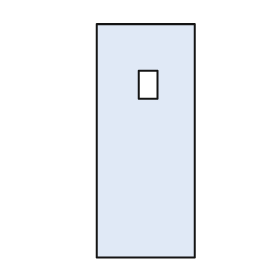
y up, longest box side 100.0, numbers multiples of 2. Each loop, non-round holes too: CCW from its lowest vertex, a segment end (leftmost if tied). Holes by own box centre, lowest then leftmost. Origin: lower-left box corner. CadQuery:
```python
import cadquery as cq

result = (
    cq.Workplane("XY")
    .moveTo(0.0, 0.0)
    .lineTo(42.0, 0.0)
    .lineTo(42.0, 100.0)
    .lineTo(0.0, 100.0)
    .close()
    .moveTo(18.0, 68.0)
    .lineTo(26.0, 68.0)
    .lineTo(26.0, 80.0)
    .lineTo(18.0, 80.0)
    .close()
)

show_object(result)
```